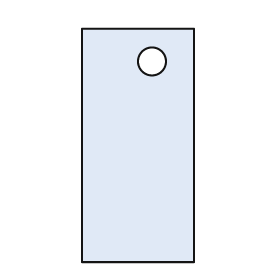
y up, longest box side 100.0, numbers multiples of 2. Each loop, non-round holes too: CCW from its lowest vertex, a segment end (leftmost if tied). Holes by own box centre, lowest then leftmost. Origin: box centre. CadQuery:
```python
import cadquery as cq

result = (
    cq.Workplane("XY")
    .moveTo(-24.0, -50.0)
    .lineTo(24.0, -50.0)
    .lineTo(24.0, 50.0)
    .lineTo(-24.0, 50.0)
    .close()
    .moveTo(6.0, 36.0)
    .circle(6.0)
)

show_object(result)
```